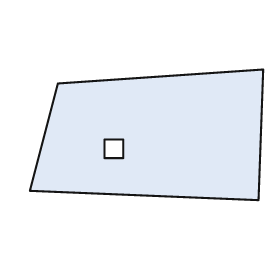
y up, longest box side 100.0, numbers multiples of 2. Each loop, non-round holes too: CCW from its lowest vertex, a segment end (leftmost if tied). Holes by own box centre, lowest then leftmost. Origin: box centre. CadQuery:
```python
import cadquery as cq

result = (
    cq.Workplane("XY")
    .moveTo(48.0, -28.0)
    .lineTo(50.0, 28.0)
    .lineTo(-38.0, 22.0)
    .lineTo(-50.0, -24.0)
    .close()
    .moveTo(-18.0, -10.0)
    .lineTo(-10.0, -10.0)
    .lineTo(-10.0, -2.0)
    .lineTo(-18.0, -2.0)
    .close()
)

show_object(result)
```